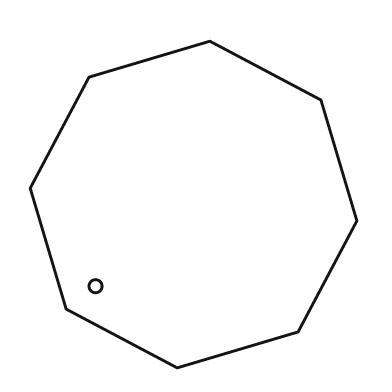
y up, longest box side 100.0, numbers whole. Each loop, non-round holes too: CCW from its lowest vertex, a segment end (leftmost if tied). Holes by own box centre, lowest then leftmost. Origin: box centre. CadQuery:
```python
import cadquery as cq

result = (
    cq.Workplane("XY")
    .moveTo(-5.0, -50.0)
    .lineTo(32.0, -39.0)
    .lineTo(50.0, -5.0)
    .lineTo(39.0, 32.0)
    .lineTo(5.0, 50.0)
    .lineTo(-32.0, 39.0)
    .lineTo(-50.0, 5.0)
    .lineTo(-39.0, -32.0)
    .close()
    .moveTo(-30.0, -25.0)
    .circle(2.0)
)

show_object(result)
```